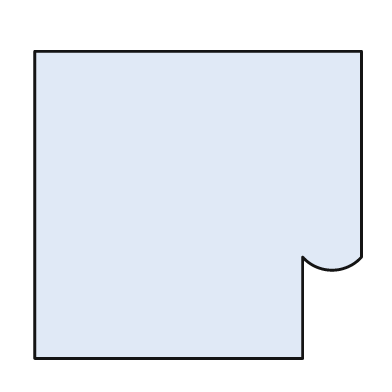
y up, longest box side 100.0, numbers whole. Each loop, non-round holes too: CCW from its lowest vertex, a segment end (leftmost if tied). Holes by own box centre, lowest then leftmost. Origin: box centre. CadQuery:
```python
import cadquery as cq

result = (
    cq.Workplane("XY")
    .moveTo(-50.0, -47.0)
    .lineTo(32.0, -47.0)
    .lineTo(32.0, -16.0)
    .threePointArc((41.0, -20.0), (50.0, -16.0))
    .lineTo(50.0, 47.0)
    .lineTo(-50.0, 47.0)
    .close()
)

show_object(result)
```